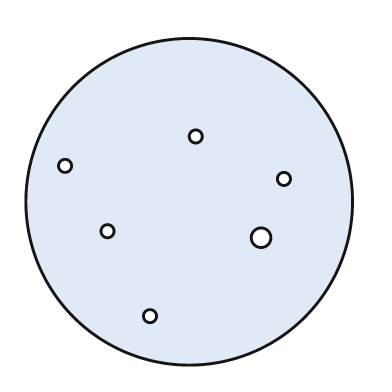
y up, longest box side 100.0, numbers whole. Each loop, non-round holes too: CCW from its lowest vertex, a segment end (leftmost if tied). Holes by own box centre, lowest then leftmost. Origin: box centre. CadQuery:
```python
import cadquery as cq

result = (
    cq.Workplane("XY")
    .moveTo(0.0, 0.0)
    .circle(50.0)
    .moveTo(-12.0, -35.0)
    .circle(2.0)
    .moveTo(22.0, -11.0)
    .circle(3.0)
    .moveTo(-25.0, -9.0)
    .circle(2.0)
    .moveTo(29.0, 7.0)
    .circle(2.0)
    .moveTo(-38.0, 11.0)
    .circle(2.0)
    .moveTo(2.0, 20.0)
    .circle(2.0)
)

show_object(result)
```